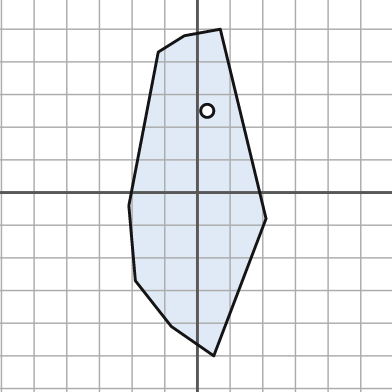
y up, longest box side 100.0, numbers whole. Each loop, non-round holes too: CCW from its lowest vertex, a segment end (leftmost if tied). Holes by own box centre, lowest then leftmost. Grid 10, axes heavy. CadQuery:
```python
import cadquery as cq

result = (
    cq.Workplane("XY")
    .moveTo(5.0, -50.0)
    .lineTo(21.0, -8.0)
    .lineTo(7.0, 50.0)
    .lineTo(-4.0, 48.0)
    .lineTo(-12.0, 43.0)
    .lineTo(-21.0, -4.0)
    .lineTo(-19.0, -27.0)
    .lineTo(-8.0, -41.0)
    .close()
    .moveTo(3.0, 25.0)
    .circle(2.0)
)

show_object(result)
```